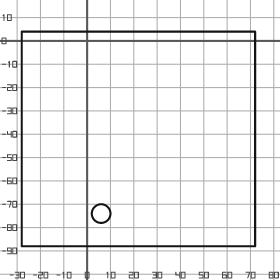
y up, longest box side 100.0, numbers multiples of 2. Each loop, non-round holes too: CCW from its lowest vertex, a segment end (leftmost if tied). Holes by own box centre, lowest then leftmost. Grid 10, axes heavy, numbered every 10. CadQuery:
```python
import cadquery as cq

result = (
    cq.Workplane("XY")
    .moveTo(-28.0, -88.0)
    .lineTo(72.0, -88.0)
    .lineTo(72.0, 4.0)
    .lineTo(-28.0, 4.0)
    .close()
    .moveTo(6.0, -74.0)
    .circle(4.0)
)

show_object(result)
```